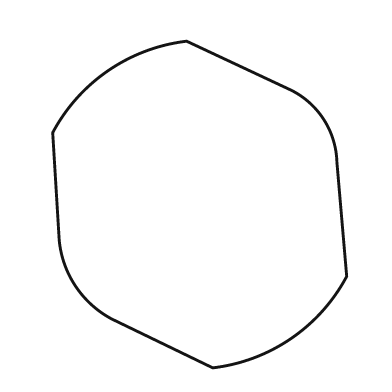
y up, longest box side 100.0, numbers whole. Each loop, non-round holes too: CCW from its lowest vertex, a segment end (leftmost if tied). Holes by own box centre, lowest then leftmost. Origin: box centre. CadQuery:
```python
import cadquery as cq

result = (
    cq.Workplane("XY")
    .moveTo(4.0, -50.0)
    .threePointArc((28.0, -41.0), (45.0, -22.0))
    .lineTo(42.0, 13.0)
    .threePointArc((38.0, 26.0), (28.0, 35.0))
    .lineTo(-4.0, 50.0)
    .threePointArc((-28.0, 41.0), (-45.0, 22.0))
    .lineTo(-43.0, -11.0)
    .threePointArc((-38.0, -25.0), (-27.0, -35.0))
    .close()
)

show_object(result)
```